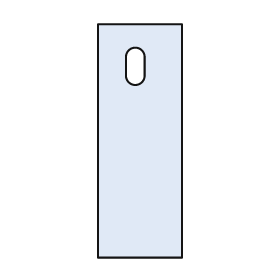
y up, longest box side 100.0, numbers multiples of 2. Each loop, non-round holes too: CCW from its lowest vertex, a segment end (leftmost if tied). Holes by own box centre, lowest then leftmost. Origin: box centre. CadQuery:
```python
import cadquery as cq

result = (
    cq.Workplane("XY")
    .moveTo(-18.0, -50.0)
    .lineTo(18.0, -50.0)
    .lineTo(18.0, 50.0)
    .lineTo(-18.0, 50.0)
    .close()
    .moveTo(-6.0, 28.0)
    .threePointArc((-2.0, 24.0), (2.0, 28.0))
    .lineTo(2.0, 36.0)
    .threePointArc((-2.0, 40.0), (-6.0, 36.0))
    .close()
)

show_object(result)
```